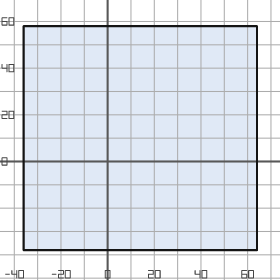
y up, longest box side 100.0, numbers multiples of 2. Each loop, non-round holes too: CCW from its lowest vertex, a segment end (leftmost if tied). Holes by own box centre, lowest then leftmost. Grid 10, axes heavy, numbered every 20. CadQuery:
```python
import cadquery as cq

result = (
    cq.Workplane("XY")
    .moveTo(-36.0, -38.0)
    .lineTo(64.0, -38.0)
    .lineTo(64.0, 58.0)
    .lineTo(-36.0, 58.0)
    .close()
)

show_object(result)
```